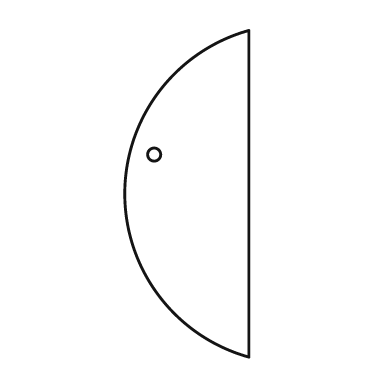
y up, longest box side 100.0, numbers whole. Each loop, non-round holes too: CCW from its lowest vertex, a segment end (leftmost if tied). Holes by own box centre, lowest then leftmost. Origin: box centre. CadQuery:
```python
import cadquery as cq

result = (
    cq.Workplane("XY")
    .moveTo(19.0, -50.0)
    .lineTo(19.0, 50.0)
    .threePointArc((-19.0, 0.0), (19.0, -50.0))
    .close()
    .moveTo(-10.0, 12.0)
    .circle(2.0)
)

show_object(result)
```